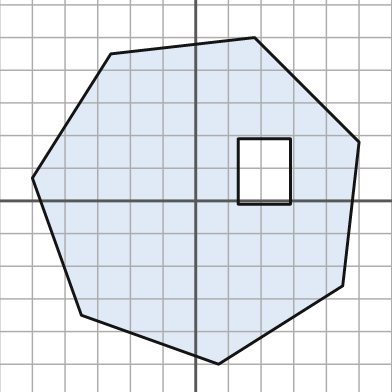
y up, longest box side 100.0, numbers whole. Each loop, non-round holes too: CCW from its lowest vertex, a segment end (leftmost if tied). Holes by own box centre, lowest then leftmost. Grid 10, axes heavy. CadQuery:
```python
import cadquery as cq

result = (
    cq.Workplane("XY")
    .moveTo(7.0, -50.0)
    .lineTo(45.0, -26.0)
    .lineTo(50.0, 18.0)
    .lineTo(18.0, 50.0)
    .lineTo(-26.0, 45.0)
    .lineTo(-50.0, 7.0)
    .lineTo(-35.0, -35.0)
    .close()
    .moveTo(13.0, -1.0)
    .lineTo(29.0, -1.0)
    .lineTo(29.0, 19.0)
    .lineTo(13.0, 19.0)
    .close()
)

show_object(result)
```